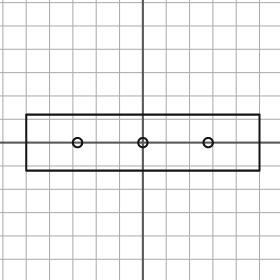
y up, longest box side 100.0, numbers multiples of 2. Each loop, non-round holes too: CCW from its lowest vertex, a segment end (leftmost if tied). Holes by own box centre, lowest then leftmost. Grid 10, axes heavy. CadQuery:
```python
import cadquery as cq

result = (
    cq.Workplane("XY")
    .moveTo(-50.0, -12.0)
    .lineTo(50.0, -12.0)
    .lineTo(50.0, 12.0)
    .lineTo(-50.0, 12.0)
    .close()
    .moveTo(-28.0, 0.0)
    .circle(2.0)
    .moveTo(0.0, 0.0)
    .circle(2.0)
    .moveTo(28.0, 0.0)
    .circle(2.0)
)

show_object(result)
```